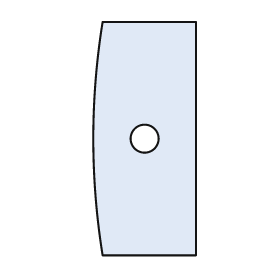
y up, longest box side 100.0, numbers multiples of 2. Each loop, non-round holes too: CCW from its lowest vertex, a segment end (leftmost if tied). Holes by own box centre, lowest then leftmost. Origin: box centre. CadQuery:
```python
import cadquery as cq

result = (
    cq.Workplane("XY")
    .moveTo(-18.0, -50.0)
    .lineTo(22.0, -50.0)
    .lineTo(22.0, 50.0)
    .lineTo(-18.0, 50.0)
    .threePointArc((-22.0, 0.0), (-18.0, -50.0))
    .close()
    .moveTo(0.0, 0.0)
    .circle(6.0)
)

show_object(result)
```